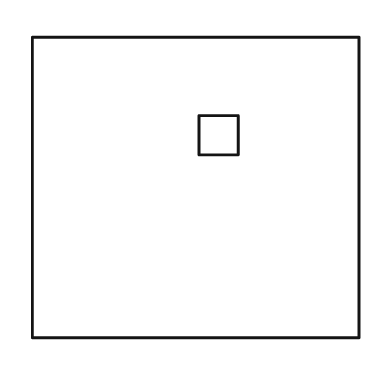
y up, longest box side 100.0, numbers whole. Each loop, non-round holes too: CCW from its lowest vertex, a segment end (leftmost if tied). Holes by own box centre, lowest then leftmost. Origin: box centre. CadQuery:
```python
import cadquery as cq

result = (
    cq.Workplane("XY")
    .moveTo(-50.0, -46.0)
    .lineTo(50.0, -46.0)
    .lineTo(50.0, 46.0)
    .lineTo(-50.0, 46.0)
    .close()
    .moveTo(1.0, 10.0)
    .lineTo(13.0, 10.0)
    .lineTo(13.0, 22.0)
    .lineTo(1.0, 22.0)
    .close()
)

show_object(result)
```